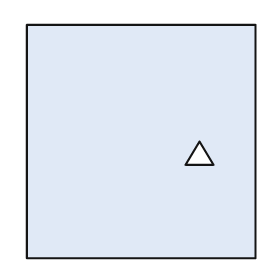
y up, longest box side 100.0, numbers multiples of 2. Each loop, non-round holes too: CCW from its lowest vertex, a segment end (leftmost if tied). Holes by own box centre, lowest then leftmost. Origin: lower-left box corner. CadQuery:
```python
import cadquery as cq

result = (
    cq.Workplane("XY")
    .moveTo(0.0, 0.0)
    .lineTo(98.0, 0.0)
    .lineTo(98.0, 100.0)
    .lineTo(0.0, 100.0)
    .close()
    .moveTo(68.0, 40.0)
    .lineTo(80.0, 40.0)
    .lineTo(74.0, 50.0)
    .close()
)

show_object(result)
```